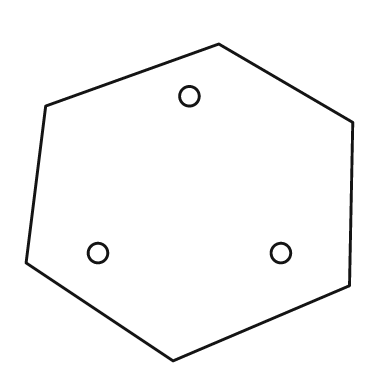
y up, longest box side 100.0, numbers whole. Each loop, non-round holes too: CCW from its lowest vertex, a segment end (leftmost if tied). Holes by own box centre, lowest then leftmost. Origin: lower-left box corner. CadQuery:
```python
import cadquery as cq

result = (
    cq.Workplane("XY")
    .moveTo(45.0, 0.0)
    .lineTo(99.0, 23.0)
    .lineTo(100.0, 73.0)
    .lineTo(59.0, 97.0)
    .lineTo(6.0, 78.0)
    .lineTo(0.0, 30.0)
    .close()
    .moveTo(22.0, 33.0)
    .circle(3.0)
    .moveTo(78.0, 33.0)
    .circle(3.0)
    .moveTo(50.0, 81.0)
    .circle(3.0)
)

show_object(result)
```